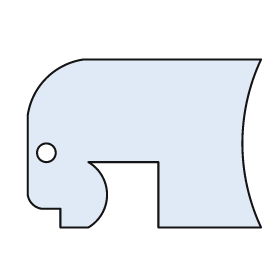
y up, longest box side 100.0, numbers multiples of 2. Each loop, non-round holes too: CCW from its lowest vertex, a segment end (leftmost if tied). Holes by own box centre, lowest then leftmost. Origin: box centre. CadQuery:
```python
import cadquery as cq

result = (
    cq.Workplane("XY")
    .moveTo(-36.0, -36.0)
    .lineTo(-24.0, -36.0)
    .threePointArc((-16.0, -22.0), (-24.0, -8.0))
    .lineTo(6.0, -8.0)
    .lineTo(6.0, -36.0)
    .lineTo(50.0, -36.0)
    .threePointArc((42.0, 0.0), (50.0, 36.0))
    .lineTo(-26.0, 36.0)
    .threePointArc((-42.0, 28.0), (-50.0, 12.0))
    .lineTo(-50.0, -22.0)
    .threePointArc((-48.0, -26.0), (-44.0, -28.0))
    .lineTo(-36.0, -28.0)
    .close()
    .moveTo(-42.0, -4.0)
    .circle(4.0)
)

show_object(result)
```